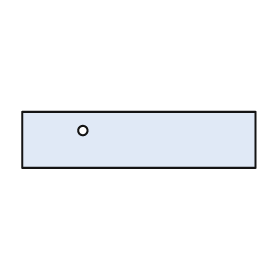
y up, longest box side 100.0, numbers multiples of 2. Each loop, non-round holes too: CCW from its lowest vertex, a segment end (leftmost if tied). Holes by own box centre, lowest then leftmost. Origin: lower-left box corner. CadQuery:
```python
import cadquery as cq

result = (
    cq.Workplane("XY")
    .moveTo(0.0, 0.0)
    .lineTo(100.0, 0.0)
    .lineTo(100.0, 24.0)
    .lineTo(0.0, 24.0)
    .close()
    .moveTo(26.0, 16.0)
    .circle(2.0)
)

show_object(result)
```